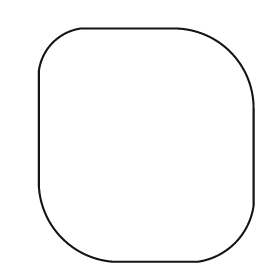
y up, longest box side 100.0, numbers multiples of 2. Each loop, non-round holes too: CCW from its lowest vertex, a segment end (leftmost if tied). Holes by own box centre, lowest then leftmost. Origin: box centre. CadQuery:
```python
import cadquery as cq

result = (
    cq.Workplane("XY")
    .moveTo(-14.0, -50.0)
    .lineTo(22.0, -50.0)
    .threePointArc((38.0, -42.0), (46.0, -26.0))
    .lineTo(46.0, 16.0)
    .threePointArc((36.0, 40.0), (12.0, 50.0))
    .lineTo(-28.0, 50.0)
    .threePointArc((-40.0, 44.0), (-46.0, 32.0))
    .lineTo(-46.0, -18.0)
    .threePointArc((-36.0, -40.0), (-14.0, -50.0))
    .close()
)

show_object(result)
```